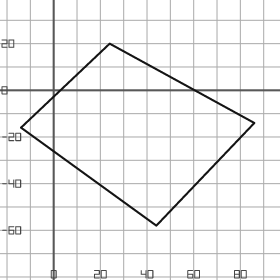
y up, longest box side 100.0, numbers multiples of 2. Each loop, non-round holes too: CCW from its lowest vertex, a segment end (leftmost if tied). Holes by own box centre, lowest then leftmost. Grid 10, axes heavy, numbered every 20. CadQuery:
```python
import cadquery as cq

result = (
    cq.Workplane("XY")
    .moveTo(44.0, -58.0)
    .lineTo(86.0, -14.0)
    .lineTo(24.0, 20.0)
    .lineTo(-14.0, -16.0)
    .close()
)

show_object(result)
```